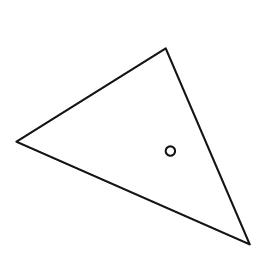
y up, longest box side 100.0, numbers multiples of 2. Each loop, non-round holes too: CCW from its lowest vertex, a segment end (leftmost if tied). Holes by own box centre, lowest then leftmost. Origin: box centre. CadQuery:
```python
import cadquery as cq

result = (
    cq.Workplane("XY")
    .moveTo(50.0, -42.0)
    .lineTo(14.0, 42.0)
    .lineTo(-50.0, 2.0)
    .close()
    .moveTo(16.0, -2.0)
    .circle(2.0)
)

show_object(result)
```